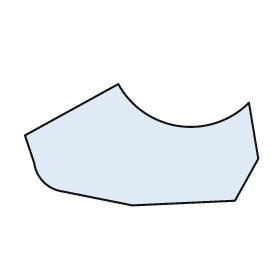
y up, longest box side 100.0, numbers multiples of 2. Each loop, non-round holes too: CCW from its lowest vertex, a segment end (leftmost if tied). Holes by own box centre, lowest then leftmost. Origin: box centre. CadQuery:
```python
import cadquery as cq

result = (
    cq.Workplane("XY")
    .moveTo(-4.0, -26.0)
    .lineTo(40.0, -24.0)
    .lineTo(50.0, -6.0)
    .lineTo(46.0, 18.0)
    .threePointArc((16.0, 8.0), (-10.0, 26.0))
    .lineTo(-50.0, 4.0)
    .lineTo(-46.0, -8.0)
    .threePointArc((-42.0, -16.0), (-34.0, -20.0))
    .close()
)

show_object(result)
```